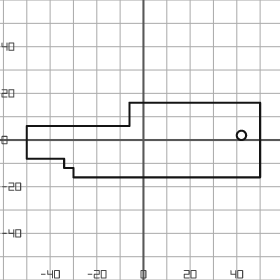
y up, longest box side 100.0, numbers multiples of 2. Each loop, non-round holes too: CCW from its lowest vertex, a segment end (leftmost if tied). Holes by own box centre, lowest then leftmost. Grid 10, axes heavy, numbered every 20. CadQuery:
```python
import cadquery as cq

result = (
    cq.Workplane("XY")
    .moveTo(-30.0, -16.0)
    .lineTo(50.0, -16.0)
    .lineTo(50.0, 16.0)
    .lineTo(-6.0, 16.0)
    .lineTo(-6.0, 6.0)
    .lineTo(-50.0, 6.0)
    .lineTo(-50.0, -8.0)
    .lineTo(-34.0, -8.0)
    .lineTo(-34.0, -12.0)
    .lineTo(-30.0, -12.0)
    .close()
    .moveTo(42.0, 2.0)
    .circle(2.0)
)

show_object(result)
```